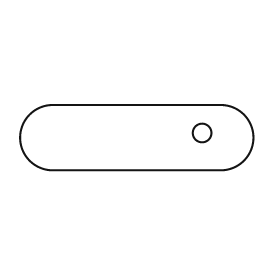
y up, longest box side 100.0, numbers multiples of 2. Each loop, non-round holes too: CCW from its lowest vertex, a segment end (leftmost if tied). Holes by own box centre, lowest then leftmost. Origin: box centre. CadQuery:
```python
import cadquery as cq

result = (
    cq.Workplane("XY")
    .moveTo(-36.0, -14.0)
    .lineTo(36.0, -14.0)
    .threePointArc((50.0, 0.0), (36.0, 14.0))
    .lineTo(-36.0, 14.0)
    .threePointArc((-50.0, 0.0), (-36.0, -14.0))
    .close()
    .moveTo(28.0, 2.0)
    .circle(4.0)
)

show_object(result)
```